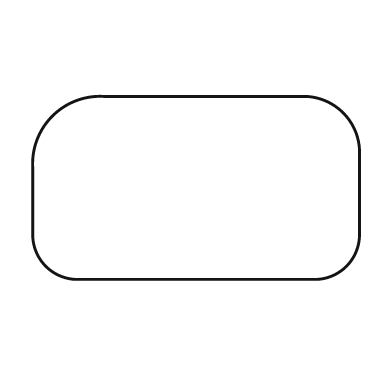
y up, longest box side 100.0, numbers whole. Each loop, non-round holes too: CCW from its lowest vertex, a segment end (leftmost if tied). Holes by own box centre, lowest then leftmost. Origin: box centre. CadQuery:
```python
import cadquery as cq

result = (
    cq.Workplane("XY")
    .moveTo(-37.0, -28.0)
    .lineTo(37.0, -28.0)
    .threePointArc((46.0, -24.0), (50.0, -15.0))
    .lineTo(50.0, 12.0)
    .threePointArc((45.0, 23.0), (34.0, 28.0))
    .lineTo(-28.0, 28.0)
    .threePointArc((-44.0, 22.0), (-50.0, 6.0))
    .lineTo(-50.0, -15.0)
    .threePointArc((-46.0, -24.0), (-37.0, -28.0))
    .close()
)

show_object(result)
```